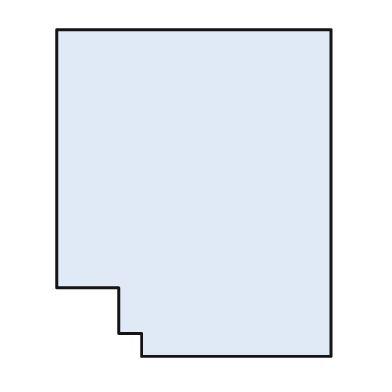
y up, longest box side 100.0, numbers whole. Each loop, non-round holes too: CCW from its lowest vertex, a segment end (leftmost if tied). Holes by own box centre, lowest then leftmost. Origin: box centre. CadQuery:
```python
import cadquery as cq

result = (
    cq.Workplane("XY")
    .moveTo(-16.0, -50.0)
    .lineTo(42.0, -50.0)
    .lineTo(42.0, 50.0)
    .lineTo(-42.0, 50.0)
    .lineTo(-42.0, -29.0)
    .lineTo(-23.0, -29.0)
    .lineTo(-23.0, -43.0)
    .lineTo(-16.0, -43.0)
    .close()
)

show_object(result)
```